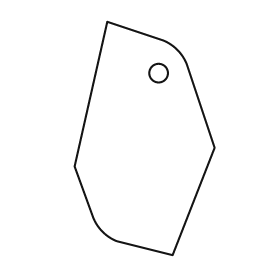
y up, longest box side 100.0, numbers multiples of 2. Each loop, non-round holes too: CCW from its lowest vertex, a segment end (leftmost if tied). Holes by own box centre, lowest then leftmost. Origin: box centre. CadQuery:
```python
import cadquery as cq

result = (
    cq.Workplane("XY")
    .moveTo(12.0, -50.0)
    .lineTo(30.0, -4.0)
    .lineTo(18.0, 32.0)
    .threePointArc((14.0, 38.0), (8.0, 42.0))
    .lineTo(-16.0, 50.0)
    .lineTo(-30.0, -12.0)
    .lineTo(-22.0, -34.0)
    .threePointArc((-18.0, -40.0), (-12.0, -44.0))
    .close()
    .moveTo(6.0, 28.0)
    .circle(4.0)
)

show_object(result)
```